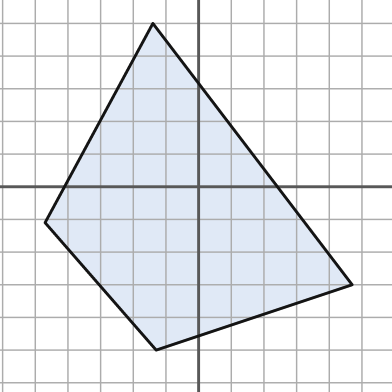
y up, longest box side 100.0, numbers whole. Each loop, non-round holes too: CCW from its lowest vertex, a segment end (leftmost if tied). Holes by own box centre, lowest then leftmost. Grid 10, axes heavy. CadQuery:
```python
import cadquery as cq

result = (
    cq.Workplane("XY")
    .moveTo(-13.0, -50.0)
    .lineTo(47.0, -30.0)
    .lineTo(-14.0, 50.0)
    .lineTo(-47.0, -11.0)
    .close()
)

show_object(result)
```